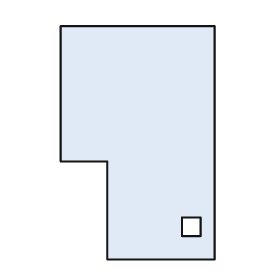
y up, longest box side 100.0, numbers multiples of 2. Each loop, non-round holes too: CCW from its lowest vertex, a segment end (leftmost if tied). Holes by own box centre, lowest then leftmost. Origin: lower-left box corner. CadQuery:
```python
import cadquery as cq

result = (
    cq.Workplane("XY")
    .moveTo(20.0, 0.0)
    .lineTo(66.0, 0.0)
    .lineTo(66.0, 100.0)
    .lineTo(0.0, 100.0)
    .lineTo(0.0, 42.0)
    .lineTo(20.0, 42.0)
    .close()
    .moveTo(52.0, 10.0)
    .lineTo(60.0, 10.0)
    .lineTo(60.0, 18.0)
    .lineTo(52.0, 18.0)
    .close()
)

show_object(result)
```